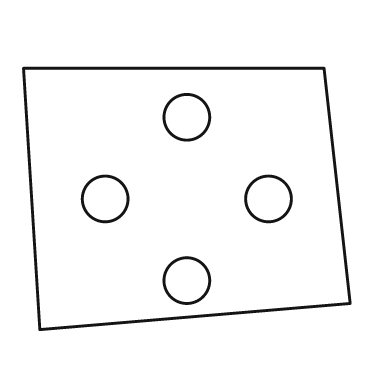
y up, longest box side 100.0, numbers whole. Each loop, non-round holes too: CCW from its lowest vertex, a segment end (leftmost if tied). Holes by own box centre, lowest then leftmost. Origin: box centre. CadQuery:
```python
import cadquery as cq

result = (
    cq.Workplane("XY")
    .moveTo(-45.0, -40.0)
    .lineTo(50.0, -32.0)
    .lineTo(42.0, 40.0)
    .lineTo(-50.0, 40.0)
    .close()
    .moveTo(0.0, -25.0)
    .circle(7.0)
    .moveTo(-25.0, 0.0)
    .circle(7.0)
    .moveTo(25.0, 0.0)
    .circle(7.0)
    .moveTo(0.0, 25.0)
    .circle(7.0)
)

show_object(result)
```